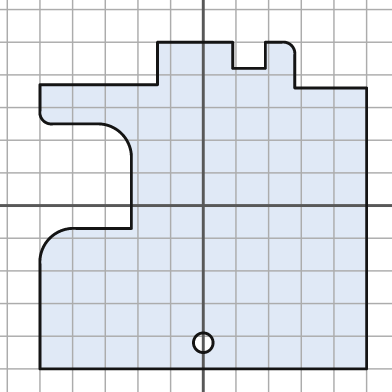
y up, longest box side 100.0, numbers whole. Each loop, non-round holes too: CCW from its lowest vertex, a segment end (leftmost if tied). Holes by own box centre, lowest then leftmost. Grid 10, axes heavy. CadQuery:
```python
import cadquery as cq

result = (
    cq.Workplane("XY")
    .moveTo(-50.0, -50.0)
    .lineTo(50.0, -50.0)
    .lineTo(50.0, 36.0)
    .lineTo(28.0, 36.0)
    .lineTo(28.0, 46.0)
    .threePointArc((27.0, 49.0), (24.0, 50.0))
    .lineTo(19.0, 50.0)
    .lineTo(19.0, 42.0)
    .lineTo(9.0, 42.0)
    .lineTo(9.0, 50.0)
    .lineTo(-14.0, 50.0)
    .lineTo(-14.0, 37.0)
    .lineTo(-50.0, 37.0)
    .lineTo(-50.0, 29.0)
    .threePointArc((-49.0, 26.0), (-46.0, 25.0))
    .lineTo(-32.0, 25.0)
    .threePointArc((-25.0, 22.0), (-22.0, 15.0))
    .lineTo(-22.0, -7.0)
    .lineTo(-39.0, -7.0)
    .threePointArc((-47.0, -10.0), (-50.0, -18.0))
    .close()
    .moveTo(0.0, -42.0)
    .circle(3.0)
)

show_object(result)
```